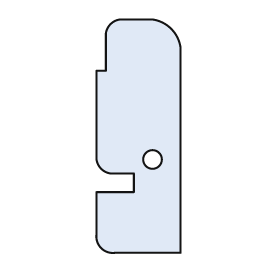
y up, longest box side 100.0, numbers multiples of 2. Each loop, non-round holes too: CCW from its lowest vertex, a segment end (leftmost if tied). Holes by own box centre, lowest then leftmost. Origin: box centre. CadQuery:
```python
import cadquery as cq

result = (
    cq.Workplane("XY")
    .moveTo(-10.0, -50.0)
    .lineTo(18.0, -50.0)
    .lineTo(18.0, 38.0)
    .threePointArc((14.0, 46.0), (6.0, 50.0))
    .lineTo(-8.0, 50.0)
    .threePointArc((-12.0, 48.0), (-14.0, 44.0))
    .lineTo(-14.0, 28.0)
    .lineTo(-18.0, 28.0)
    .lineTo(-18.0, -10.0)
    .threePointArc((-16.0, -14.0), (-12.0, -16.0))
    .lineTo(-2.0, -16.0)
    .lineTo(-2.0, -24.0)
    .lineTo(-18.0, -24.0)
    .lineTo(-18.0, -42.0)
    .threePointArc((-16.0, -48.0), (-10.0, -50.0))
    .close()
    .moveTo(6.0, -10.0)
    .circle(4.0)
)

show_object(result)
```